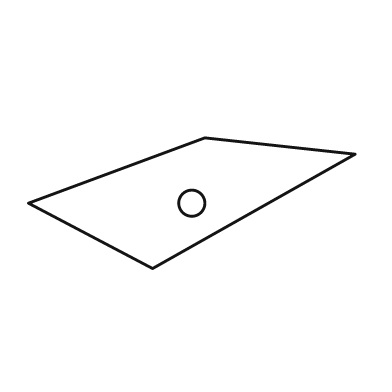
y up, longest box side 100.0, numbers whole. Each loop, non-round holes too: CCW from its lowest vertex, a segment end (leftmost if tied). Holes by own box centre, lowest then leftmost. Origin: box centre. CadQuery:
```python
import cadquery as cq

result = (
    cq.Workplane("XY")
    .moveTo(-12.0, -20.0)
    .lineTo(50.0, 15.0)
    .lineTo(4.0, 20.0)
    .lineTo(-50.0, 0.0)
    .close()
    .moveTo(0.0, 0.0)
    .circle(4.0)
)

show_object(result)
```